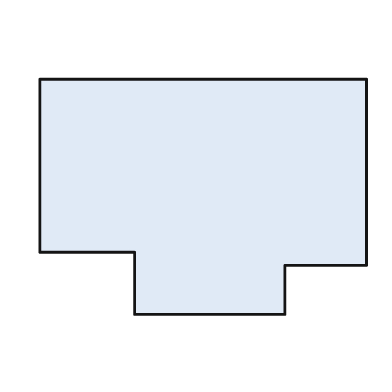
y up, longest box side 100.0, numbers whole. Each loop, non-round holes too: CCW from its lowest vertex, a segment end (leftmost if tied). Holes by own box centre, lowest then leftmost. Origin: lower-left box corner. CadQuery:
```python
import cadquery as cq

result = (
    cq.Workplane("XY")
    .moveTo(29.0, 0.0)
    .lineTo(75.0, 0.0)
    .lineTo(75.0, 15.0)
    .lineTo(100.0, 15.0)
    .lineTo(100.0, 72.0)
    .lineTo(0.0, 72.0)
    .lineTo(0.0, 19.0)
    .lineTo(29.0, 19.0)
    .close()
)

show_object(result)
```